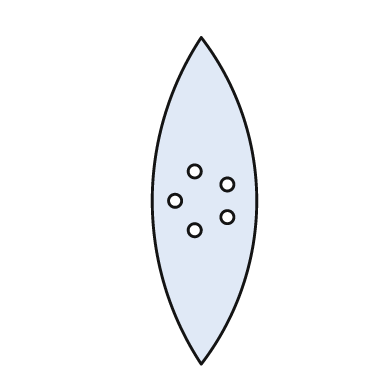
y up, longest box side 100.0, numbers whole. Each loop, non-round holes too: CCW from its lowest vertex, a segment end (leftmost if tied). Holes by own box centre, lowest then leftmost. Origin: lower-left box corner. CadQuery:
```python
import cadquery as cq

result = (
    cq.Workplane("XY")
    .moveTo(15.0, 0.0)
    .threePointArc((32.0, 50.0), (15.0, 100.0))
    .threePointArc((0.0, 50.0), (15.0, 0.0))
    .close()
    .moveTo(13.0, 41.0)
    .circle(2.0)
    .moveTo(23.0, 45.0)
    .circle(2.0)
    .moveTo(7.0, 50.0)
    .circle(2.0)
    .moveTo(23.0, 55.0)
    .circle(2.0)
    .moveTo(13.0, 59.0)
    .circle(2.0)
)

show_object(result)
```